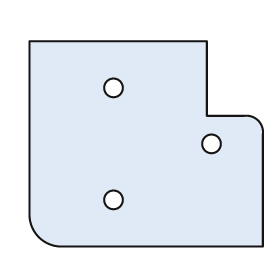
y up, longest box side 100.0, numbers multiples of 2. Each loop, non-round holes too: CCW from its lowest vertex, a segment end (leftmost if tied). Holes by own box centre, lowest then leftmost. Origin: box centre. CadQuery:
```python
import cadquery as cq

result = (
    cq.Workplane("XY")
    .moveTo(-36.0, -44.0)
    .lineTo(50.0, -44.0)
    .lineTo(50.0, 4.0)
    .threePointArc((48.0, 10.0), (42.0, 12.0))
    .lineTo(26.0, 12.0)
    .lineTo(26.0, 44.0)
    .lineTo(-50.0, 44.0)
    .lineTo(-50.0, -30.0)
    .threePointArc((-46.0, -40.0), (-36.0, -44.0))
    .close()
    .moveTo(-14.0, -24.0)
    .circle(4.0)
    .moveTo(28.0, 0.0)
    .circle(4.0)
    .moveTo(-14.0, 24.0)
    .circle(4.0)
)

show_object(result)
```